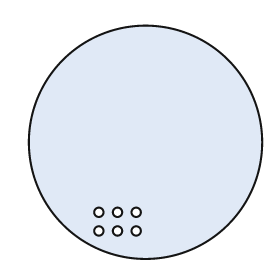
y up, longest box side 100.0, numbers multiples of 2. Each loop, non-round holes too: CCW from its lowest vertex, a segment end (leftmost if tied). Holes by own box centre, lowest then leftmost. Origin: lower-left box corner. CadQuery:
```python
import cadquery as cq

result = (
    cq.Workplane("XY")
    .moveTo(50.0, 50.0)
    .circle(50.0)
    .moveTo(30.0, 12.0)
    .circle(2.0)
    .moveTo(38.0, 12.0)
    .circle(2.0)
    .moveTo(46.0, 12.0)
    .circle(2.0)
    .moveTo(30.0, 20.0)
    .circle(2.0)
    .moveTo(38.0, 20.0)
    .circle(2.0)
    .moveTo(46.0, 20.0)
    .circle(2.0)
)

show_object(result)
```